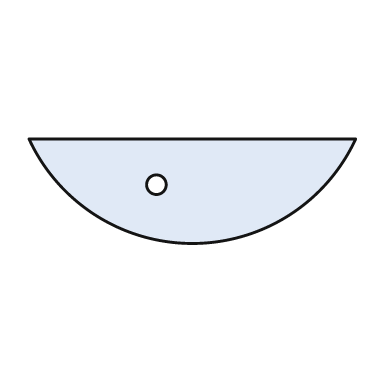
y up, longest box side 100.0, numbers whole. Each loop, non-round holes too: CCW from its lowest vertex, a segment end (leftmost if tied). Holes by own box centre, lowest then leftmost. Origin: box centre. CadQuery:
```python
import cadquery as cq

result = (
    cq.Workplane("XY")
    .moveTo(-50.0, 16.0)
    .threePointArc((0.0, -16.0), (50.0, 16.0))
    .close()
    .moveTo(-11.0, 2.0)
    .circle(3.0)
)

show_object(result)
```